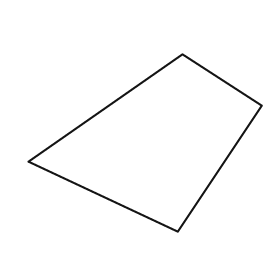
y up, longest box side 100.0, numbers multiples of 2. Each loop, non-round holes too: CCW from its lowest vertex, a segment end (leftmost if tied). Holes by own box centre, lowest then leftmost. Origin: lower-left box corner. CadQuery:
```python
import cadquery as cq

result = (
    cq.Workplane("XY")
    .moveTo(64.0, 0.0)
    .lineTo(100.0, 54.0)
    .lineTo(66.0, 76.0)
    .lineTo(0.0, 30.0)
    .close()
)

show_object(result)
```